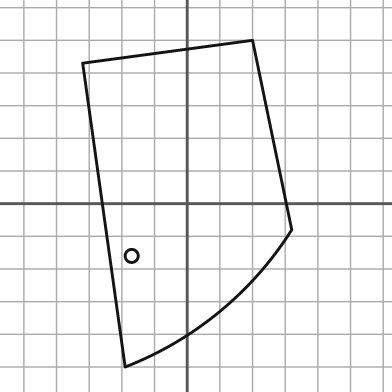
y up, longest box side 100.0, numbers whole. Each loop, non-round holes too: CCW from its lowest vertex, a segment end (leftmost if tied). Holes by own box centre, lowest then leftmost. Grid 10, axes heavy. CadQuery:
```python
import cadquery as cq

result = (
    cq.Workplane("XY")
    .moveTo(-19.0, -50.0)
    .threePointArc((10.0, -33.0), (32.0, -8.0))
    .lineTo(20.0, 50.0)
    .lineTo(-32.0, 43.0)
    .close()
    .moveTo(-17.0, -16.0)
    .circle(2.0)
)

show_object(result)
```